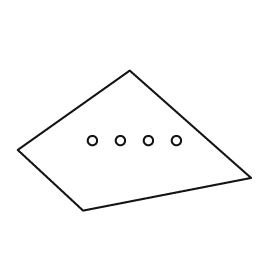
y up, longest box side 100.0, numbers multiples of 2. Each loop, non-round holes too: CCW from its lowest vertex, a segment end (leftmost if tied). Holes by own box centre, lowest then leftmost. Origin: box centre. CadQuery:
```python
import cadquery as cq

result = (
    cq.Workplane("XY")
    .moveTo(-22.0, -30.0)
    .lineTo(50.0, -16.0)
    .lineTo(-2.0, 30.0)
    .lineTo(-50.0, -4.0)
    .close()
    .moveTo(-18.0, 0.0)
    .circle(2.0)
    .moveTo(-6.0, 0.0)
    .circle(2.0)
    .moveTo(6.0, 0.0)
    .circle(2.0)
    .moveTo(18.0, 0.0)
    .circle(2.0)
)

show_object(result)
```